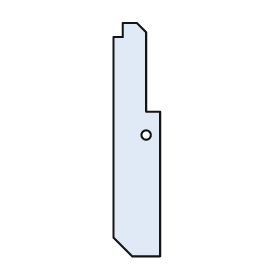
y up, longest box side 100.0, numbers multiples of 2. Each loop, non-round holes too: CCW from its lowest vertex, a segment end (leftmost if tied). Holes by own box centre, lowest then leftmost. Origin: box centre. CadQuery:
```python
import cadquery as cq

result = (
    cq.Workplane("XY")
    .moveTo(-2.0, -50.0)
    .lineTo(10.0, -50.0)
    .lineTo(10.0, 12.0)
    .lineTo(4.0, 12.0)
    .lineTo(4.0, 46.0)
    .lineTo(0.0, 50.0)
    .lineTo(-6.0, 50.0)
    .lineTo(-6.0, 44.0)
    .lineTo(-10.0, 44.0)
    .lineTo(-10.0, -42.0)
    .close()
    .moveTo(4.0, 2.0)
    .circle(2.0)
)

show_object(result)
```